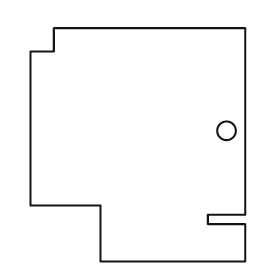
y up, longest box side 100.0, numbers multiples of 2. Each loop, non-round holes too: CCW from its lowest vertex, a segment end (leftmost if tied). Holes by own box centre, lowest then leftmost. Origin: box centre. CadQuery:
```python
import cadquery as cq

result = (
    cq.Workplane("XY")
    .moveTo(-16.0, -50.0)
    .lineTo(46.0, -50.0)
    .lineTo(46.0, -34.0)
    .lineTo(30.0, -34.0)
    .lineTo(30.0, -30.0)
    .lineTo(46.0, -30.0)
    .lineTo(46.0, 50.0)
    .lineTo(-36.0, 50.0)
    .lineTo(-36.0, 40.0)
    .lineTo(-46.0, 40.0)
    .lineTo(-46.0, -26.0)
    .lineTo(-16.0, -26.0)
    .close()
    .moveTo(38.0, 6.0)
    .circle(4.0)
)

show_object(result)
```